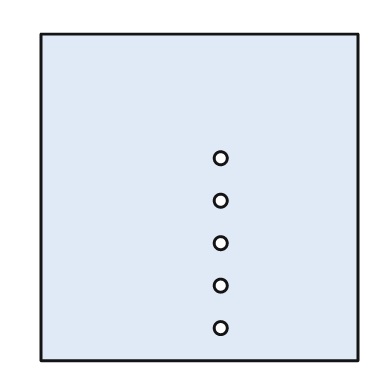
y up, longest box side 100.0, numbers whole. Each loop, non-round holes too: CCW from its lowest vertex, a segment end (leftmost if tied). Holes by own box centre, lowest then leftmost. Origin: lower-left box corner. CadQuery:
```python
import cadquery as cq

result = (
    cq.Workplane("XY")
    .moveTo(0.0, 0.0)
    .lineTo(97.0, 0.0)
    .lineTo(97.0, 100.0)
    .lineTo(0.0, 100.0)
    .close()
    .moveTo(55.0, 10.0)
    .circle(2.0)
    .moveTo(55.0, 23.0)
    .circle(2.0)
    .moveTo(55.0, 36.0)
    .circle(2.0)
    .moveTo(55.0, 49.0)
    .circle(2.0)
    .moveTo(55.0, 62.0)
    .circle(2.0)
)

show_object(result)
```